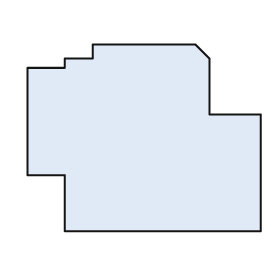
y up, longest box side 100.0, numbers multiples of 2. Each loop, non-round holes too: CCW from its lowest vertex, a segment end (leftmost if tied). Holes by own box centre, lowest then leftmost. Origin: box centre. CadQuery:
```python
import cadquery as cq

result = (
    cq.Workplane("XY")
    .moveTo(-34.0, -40.0)
    .lineTo(50.0, -40.0)
    .lineTo(50.0, 10.0)
    .lineTo(28.0, 10.0)
    .lineTo(28.0, 34.0)
    .lineTo(22.0, 40.0)
    .lineTo(-22.0, 40.0)
    .lineTo(-22.0, 34.0)
    .lineTo(-34.0, 34.0)
    .lineTo(-34.0, 30.0)
    .lineTo(-50.0, 30.0)
    .lineTo(-50.0, -16.0)
    .lineTo(-34.0, -16.0)
    .close()
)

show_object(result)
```